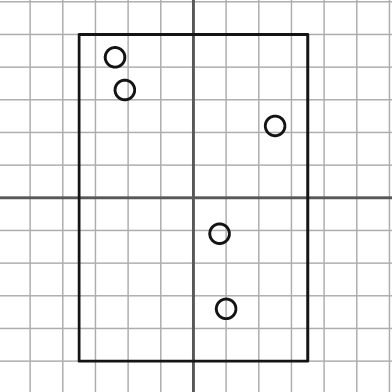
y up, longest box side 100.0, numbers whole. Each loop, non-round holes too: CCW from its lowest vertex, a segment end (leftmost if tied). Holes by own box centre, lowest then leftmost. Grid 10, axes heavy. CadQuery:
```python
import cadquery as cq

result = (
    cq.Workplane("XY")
    .moveTo(-35.0, -50.0)
    .lineTo(35.0, -50.0)
    .lineTo(35.0, 50.0)
    .lineTo(-35.0, 50.0)
    .close()
    .moveTo(10.0, -34.0)
    .circle(3.0)
    .moveTo(8.0, -11.0)
    .circle(3.0)
    .moveTo(25.0, 22.0)
    .circle(3.0)
    .moveTo(-21.0, 33.0)
    .circle(3.0)
    .moveTo(-24.0, 43.0)
    .circle(3.0)
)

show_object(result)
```